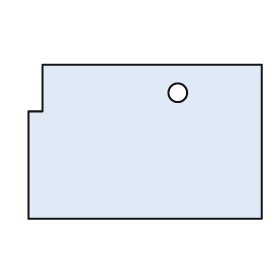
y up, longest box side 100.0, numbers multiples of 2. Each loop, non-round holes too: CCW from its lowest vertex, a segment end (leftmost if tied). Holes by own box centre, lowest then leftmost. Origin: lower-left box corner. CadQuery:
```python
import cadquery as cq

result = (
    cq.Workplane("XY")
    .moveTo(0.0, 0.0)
    .lineTo(100.0, 0.0)
    .lineTo(100.0, 66.0)
    .lineTo(6.0, 66.0)
    .lineTo(6.0, 46.0)
    .lineTo(0.0, 46.0)
    .close()
    .moveTo(64.0, 54.0)
    .circle(4.0)
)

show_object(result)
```